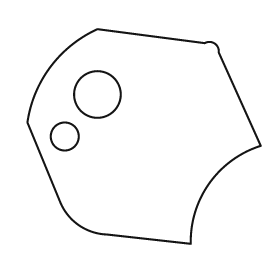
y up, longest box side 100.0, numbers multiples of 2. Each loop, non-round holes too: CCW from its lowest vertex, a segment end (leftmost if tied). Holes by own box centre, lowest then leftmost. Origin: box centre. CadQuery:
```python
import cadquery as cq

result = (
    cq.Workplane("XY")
    .moveTo(20.0, -46.0)
    .threePointArc((28.0, -20.0), (50.0, -4.0))
    .lineTo(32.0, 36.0)
    .threePointArc((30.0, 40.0), (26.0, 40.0))
    .lineTo(-20.0, 46.0)
    .threePointArc((-40.0, 30.0), (-50.0, 6.0))
    .lineTo(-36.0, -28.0)
    .threePointArc((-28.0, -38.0), (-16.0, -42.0))
    .close()
    .moveTo(-34.0, 0.0)
    .circle(6.0)
    .moveTo(-20.0, 18.0)
    .circle(10.0)
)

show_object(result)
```